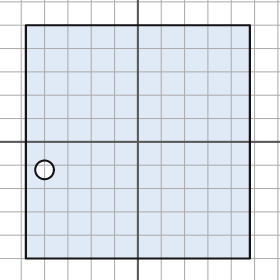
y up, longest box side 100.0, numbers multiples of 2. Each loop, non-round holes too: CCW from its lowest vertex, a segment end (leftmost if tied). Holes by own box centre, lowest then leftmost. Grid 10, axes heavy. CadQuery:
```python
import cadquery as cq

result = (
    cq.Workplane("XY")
    .moveTo(-48.0, -50.0)
    .lineTo(48.0, -50.0)
    .lineTo(48.0, 50.0)
    .lineTo(-48.0, 50.0)
    .close()
    .moveTo(-40.0, -12.0)
    .circle(4.0)
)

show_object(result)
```